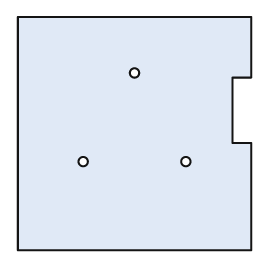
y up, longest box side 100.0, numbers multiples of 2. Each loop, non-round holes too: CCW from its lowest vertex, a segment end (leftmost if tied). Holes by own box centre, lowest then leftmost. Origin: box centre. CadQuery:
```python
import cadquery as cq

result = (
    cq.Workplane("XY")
    .moveTo(-50.0, -50.0)
    .lineTo(50.0, -50.0)
    .lineTo(50.0, -4.0)
    .lineTo(42.0, -4.0)
    .lineTo(42.0, 24.0)
    .lineTo(50.0, 24.0)
    .lineTo(50.0, 50.0)
    .lineTo(-50.0, 50.0)
    .close()
    .moveTo(-22.0, -12.0)
    .circle(2.0)
    .moveTo(22.0, -12.0)
    .circle(2.0)
    .moveTo(0.0, 26.0)
    .circle(2.0)
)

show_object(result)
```